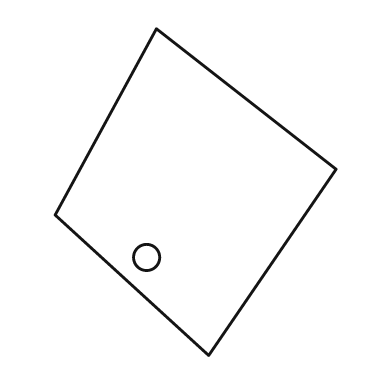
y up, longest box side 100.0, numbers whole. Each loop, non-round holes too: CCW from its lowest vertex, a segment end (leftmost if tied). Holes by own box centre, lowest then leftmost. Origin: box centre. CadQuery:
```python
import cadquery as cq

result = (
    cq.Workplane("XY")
    .moveTo(4.0, -50.0)
    .lineTo(43.0, 7.0)
    .lineTo(-12.0, 50.0)
    .lineTo(-43.0, -7.0)
    .close()
    .moveTo(-15.0, -20.0)
    .circle(4.0)
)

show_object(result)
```